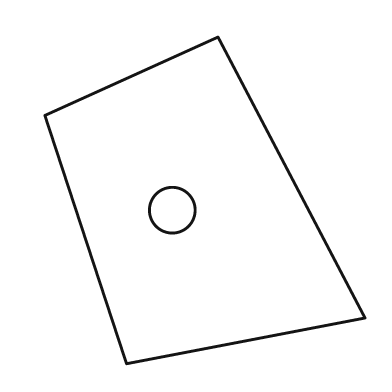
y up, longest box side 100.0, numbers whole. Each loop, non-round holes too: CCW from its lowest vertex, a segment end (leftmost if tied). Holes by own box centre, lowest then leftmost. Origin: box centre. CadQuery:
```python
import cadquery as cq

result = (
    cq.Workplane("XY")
    .moveTo(-24.0, -50.0)
    .lineTo(49.0, -36.0)
    .lineTo(4.0, 50.0)
    .lineTo(-49.0, 26.0)
    .close()
    .moveTo(-10.0, -3.0)
    .circle(7.0)
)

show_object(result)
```